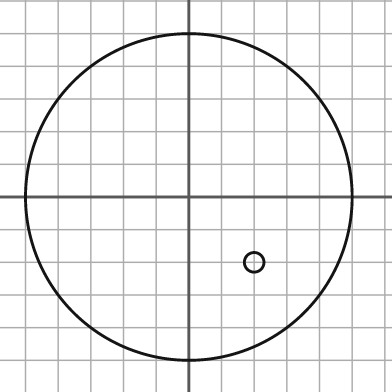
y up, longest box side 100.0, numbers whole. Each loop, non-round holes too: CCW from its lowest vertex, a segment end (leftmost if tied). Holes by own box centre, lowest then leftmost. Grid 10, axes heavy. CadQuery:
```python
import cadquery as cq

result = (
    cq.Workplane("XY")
    .moveTo(0.0, 0.0)
    .circle(50.0)
    .moveTo(20.0, -20.0)
    .circle(3.0)
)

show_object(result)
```